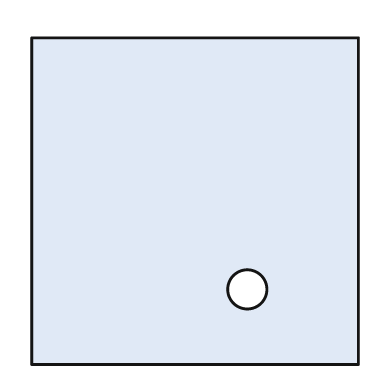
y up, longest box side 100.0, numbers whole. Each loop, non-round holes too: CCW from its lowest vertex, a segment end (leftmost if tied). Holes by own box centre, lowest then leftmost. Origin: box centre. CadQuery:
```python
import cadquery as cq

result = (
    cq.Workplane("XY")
    .moveTo(-50.0, -50.0)
    .lineTo(50.0, -50.0)
    .lineTo(50.0, 50.0)
    .lineTo(-50.0, 50.0)
    .close()
    .moveTo(16.0, -27.0)
    .circle(6.0)
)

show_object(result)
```